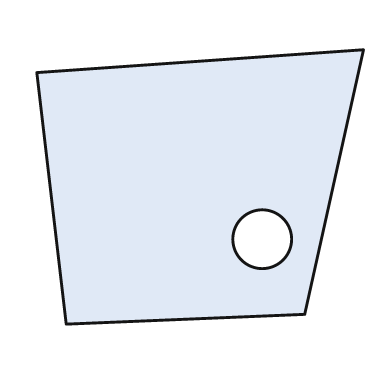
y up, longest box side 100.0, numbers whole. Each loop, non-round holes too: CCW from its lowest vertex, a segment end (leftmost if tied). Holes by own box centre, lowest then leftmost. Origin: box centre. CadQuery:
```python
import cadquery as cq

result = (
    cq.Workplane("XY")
    .moveTo(-41.0, -42.0)
    .lineTo(32.0, -39.0)
    .lineTo(50.0, 42.0)
    .lineTo(-50.0, 35.0)
    .close()
    .moveTo(19.0, -16.0)
    .circle(9.0)
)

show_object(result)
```